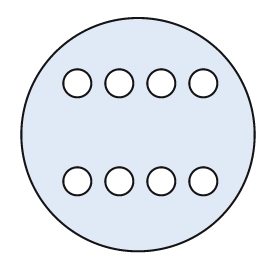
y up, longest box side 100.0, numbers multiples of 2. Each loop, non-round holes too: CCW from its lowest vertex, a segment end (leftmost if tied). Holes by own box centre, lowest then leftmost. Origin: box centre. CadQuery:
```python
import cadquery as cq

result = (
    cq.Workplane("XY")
    .moveTo(0.0, 0.0)
    .circle(50.0)
    .moveTo(-26.0, -20.0)
    .circle(6.0)
    .moveTo(-8.0, -20.0)
    .circle(6.0)
    .moveTo(10.0, -20.0)
    .circle(6.0)
    .moveTo(28.0, -20.0)
    .circle(6.0)
    .moveTo(-26.0, 22.0)
    .circle(6.0)
    .moveTo(-8.0, 22.0)
    .circle(6.0)
    .moveTo(10.0, 22.0)
    .circle(6.0)
    .moveTo(28.0, 22.0)
    .circle(6.0)
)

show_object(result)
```